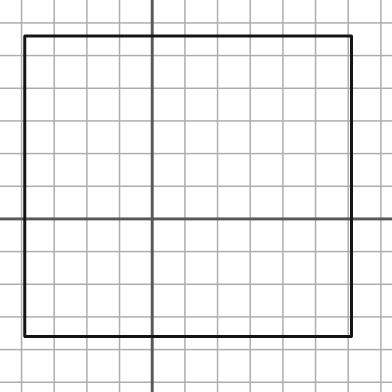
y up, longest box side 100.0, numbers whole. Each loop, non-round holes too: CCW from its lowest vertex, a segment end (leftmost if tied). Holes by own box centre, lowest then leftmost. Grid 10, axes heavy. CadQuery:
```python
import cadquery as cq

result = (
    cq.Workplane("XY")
    .moveTo(-39.0, -36.0)
    .lineTo(61.0, -36.0)
    .lineTo(61.0, 56.0)
    .lineTo(-39.0, 56.0)
    .close()
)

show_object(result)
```